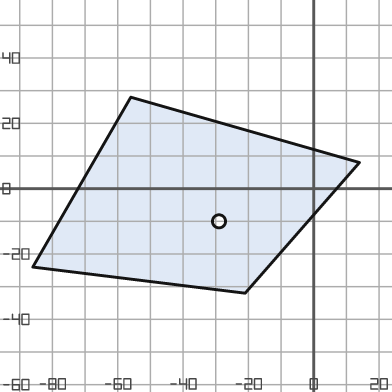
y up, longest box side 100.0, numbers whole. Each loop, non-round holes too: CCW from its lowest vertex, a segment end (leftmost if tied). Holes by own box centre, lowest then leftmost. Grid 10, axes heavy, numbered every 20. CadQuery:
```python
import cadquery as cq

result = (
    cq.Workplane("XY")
    .moveTo(-21.0, -32.0)
    .lineTo(14.0, 8.0)
    .lineTo(-56.0, 28.0)
    .lineTo(-86.0, -24.0)
    .close()
    .moveTo(-29.0, -10.0)
    .circle(2.0)
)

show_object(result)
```